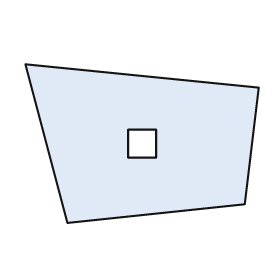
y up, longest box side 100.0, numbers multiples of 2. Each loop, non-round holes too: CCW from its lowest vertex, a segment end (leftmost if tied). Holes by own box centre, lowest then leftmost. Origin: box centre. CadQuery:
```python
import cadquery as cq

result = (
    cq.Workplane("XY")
    .moveTo(-32.0, -34.0)
    .lineTo(44.0, -26.0)
    .lineTo(50.0, 24.0)
    .lineTo(-50.0, 34.0)
    .close()
    .moveTo(-6.0, -6.0)
    .lineTo(6.0, -6.0)
    .lineTo(6.0, 6.0)
    .lineTo(-6.0, 6.0)
    .close()
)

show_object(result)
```